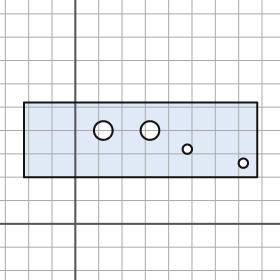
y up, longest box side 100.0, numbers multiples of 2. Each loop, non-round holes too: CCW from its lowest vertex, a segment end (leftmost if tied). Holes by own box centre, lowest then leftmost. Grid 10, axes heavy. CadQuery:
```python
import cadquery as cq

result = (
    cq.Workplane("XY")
    .moveTo(-22.0, 20.0)
    .lineTo(78.0, 20.0)
    .lineTo(78.0, 52.0)
    .lineTo(-22.0, 52.0)
    .close()
    .moveTo(72.0, 26.0)
    .circle(2.0)
    .moveTo(48.0, 32.0)
    .circle(2.0)
    .moveTo(12.0, 40.0)
    .circle(4.0)
    .moveTo(32.0, 40.0)
    .circle(4.0)
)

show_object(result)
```